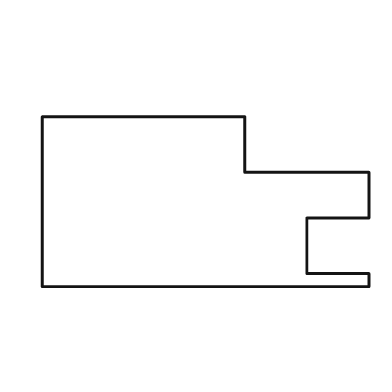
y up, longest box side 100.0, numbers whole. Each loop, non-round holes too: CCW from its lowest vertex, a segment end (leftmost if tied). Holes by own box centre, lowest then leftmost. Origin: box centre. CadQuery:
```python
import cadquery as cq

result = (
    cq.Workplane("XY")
    .moveTo(-50.0, -26.0)
    .lineTo(50.0, -26.0)
    .lineTo(50.0, -22.0)
    .lineTo(31.0, -22.0)
    .lineTo(31.0, -5.0)
    .lineTo(50.0, -5.0)
    .lineTo(50.0, 9.0)
    .lineTo(12.0, 9.0)
    .lineTo(12.0, 26.0)
    .lineTo(-50.0, 26.0)
    .close()
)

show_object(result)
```